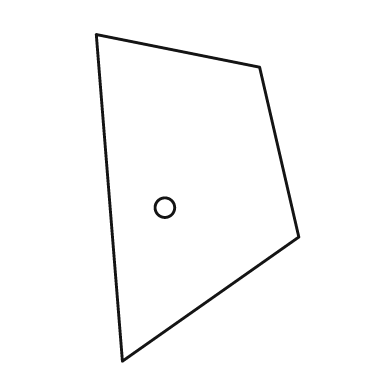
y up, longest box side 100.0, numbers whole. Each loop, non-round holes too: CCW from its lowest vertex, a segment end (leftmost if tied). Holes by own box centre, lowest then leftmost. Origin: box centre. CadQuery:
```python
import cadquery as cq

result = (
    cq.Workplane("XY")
    .moveTo(-23.0, -50.0)
    .lineTo(31.0, -12.0)
    .lineTo(19.0, 40.0)
    .lineTo(-31.0, 50.0)
    .close()
    .moveTo(-10.0, -3.0)
    .circle(3.0)
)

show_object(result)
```